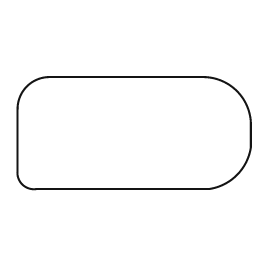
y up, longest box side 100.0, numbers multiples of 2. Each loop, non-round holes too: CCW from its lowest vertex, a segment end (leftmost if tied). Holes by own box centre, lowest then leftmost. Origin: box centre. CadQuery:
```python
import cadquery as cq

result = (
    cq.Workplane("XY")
    .moveTo(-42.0, -24.0)
    .lineTo(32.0, -24.0)
    .threePointArc((44.0, -18.0), (50.0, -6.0))
    .lineTo(50.0, 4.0)
    .threePointArc((44.0, 18.0), (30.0, 24.0))
    .lineTo(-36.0, 24.0)
    .threePointArc((-46.0, 20.0), (-50.0, 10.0))
    .lineTo(-50.0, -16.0)
    .threePointArc((-48.0, -22.0), (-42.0, -24.0))
    .close()
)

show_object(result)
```